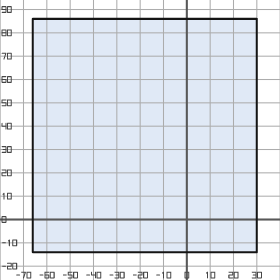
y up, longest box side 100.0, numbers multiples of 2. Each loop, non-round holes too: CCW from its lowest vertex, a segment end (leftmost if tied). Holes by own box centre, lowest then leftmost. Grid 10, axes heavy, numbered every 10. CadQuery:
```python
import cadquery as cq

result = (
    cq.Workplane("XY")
    .moveTo(-66.0, -14.0)
    .lineTo(30.0, -14.0)
    .lineTo(30.0, 86.0)
    .lineTo(-66.0, 86.0)
    .close()
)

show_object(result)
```